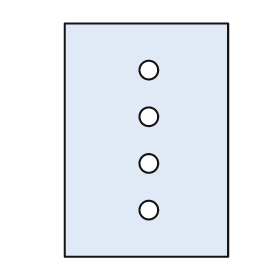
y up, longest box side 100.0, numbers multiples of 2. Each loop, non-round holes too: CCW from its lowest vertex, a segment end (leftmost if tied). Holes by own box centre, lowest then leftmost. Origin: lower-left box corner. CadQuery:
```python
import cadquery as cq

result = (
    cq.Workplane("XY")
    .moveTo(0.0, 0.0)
    .lineTo(70.0, 0.0)
    .lineTo(70.0, 100.0)
    .lineTo(0.0, 100.0)
    .close()
    .moveTo(36.0, 20.0)
    .circle(4.0)
    .moveTo(36.0, 40.0)
    .circle(4.0)
    .moveTo(36.0, 60.0)
    .circle(4.0)
    .moveTo(36.0, 80.0)
    .circle(4.0)
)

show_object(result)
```